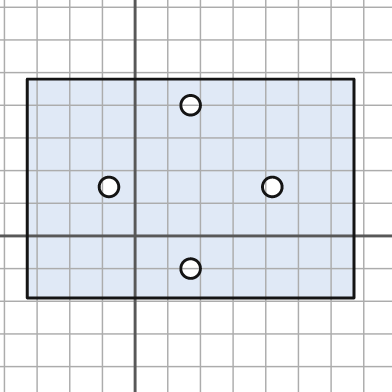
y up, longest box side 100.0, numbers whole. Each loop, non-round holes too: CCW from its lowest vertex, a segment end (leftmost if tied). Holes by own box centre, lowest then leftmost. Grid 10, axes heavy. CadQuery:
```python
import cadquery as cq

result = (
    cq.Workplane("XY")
    .moveTo(-33.0, -19.0)
    .lineTo(67.0, -19.0)
    .lineTo(67.0, 48.0)
    .lineTo(-33.0, 48.0)
    .close()
    .moveTo(17.0, -10.0)
    .circle(3.0)
    .moveTo(-8.0, 15.0)
    .circle(3.0)
    .moveTo(42.0, 15.0)
    .circle(3.0)
    .moveTo(17.0, 40.0)
    .circle(3.0)
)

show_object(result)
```